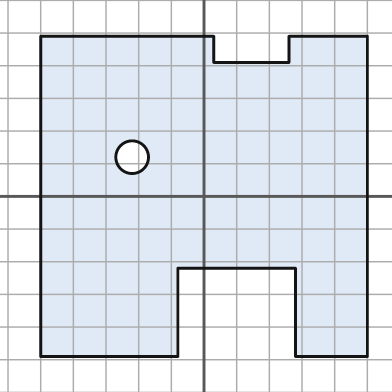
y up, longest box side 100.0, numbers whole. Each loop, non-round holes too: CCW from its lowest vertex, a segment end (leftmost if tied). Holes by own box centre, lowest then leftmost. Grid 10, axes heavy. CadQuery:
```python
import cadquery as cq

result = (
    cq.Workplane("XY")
    .moveTo(-50.0, -49.0)
    .lineTo(-8.0, -49.0)
    .lineTo(-8.0, -22.0)
    .lineTo(28.0, -22.0)
    .lineTo(28.0, -49.0)
    .lineTo(50.0, -49.0)
    .lineTo(50.0, 49.0)
    .lineTo(26.0, 49.0)
    .lineTo(26.0, 41.0)
    .lineTo(3.0, 41.0)
    .lineTo(3.0, 49.0)
    .lineTo(-50.0, 49.0)
    .close()
    .moveTo(-22.0, 12.0)
    .circle(5.0)
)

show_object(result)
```